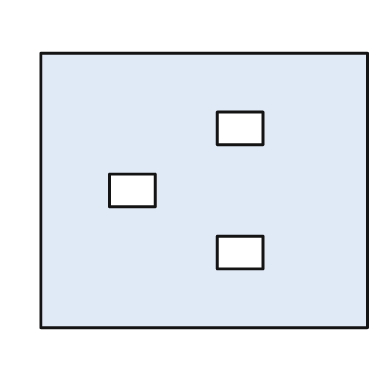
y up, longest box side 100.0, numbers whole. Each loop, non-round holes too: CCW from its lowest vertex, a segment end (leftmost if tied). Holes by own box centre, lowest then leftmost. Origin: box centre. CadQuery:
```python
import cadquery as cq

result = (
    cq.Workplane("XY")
    .moveTo(-50.0, -42.0)
    .lineTo(50.0, -42.0)
    .lineTo(50.0, 42.0)
    .lineTo(-50.0, 42.0)
    .close()
    .moveTo(4.0, -24.0)
    .lineTo(18.0, -24.0)
    .lineTo(18.0, -14.0)
    .lineTo(4.0, -14.0)
    .close()
    .moveTo(-29.0, -5.0)
    .lineTo(-15.0, -5.0)
    .lineTo(-15.0, 5.0)
    .lineTo(-29.0, 5.0)
    .close()
    .moveTo(4.0, 14.0)
    .lineTo(18.0, 14.0)
    .lineTo(18.0, 24.0)
    .lineTo(4.0, 24.0)
    .close()
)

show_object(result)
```